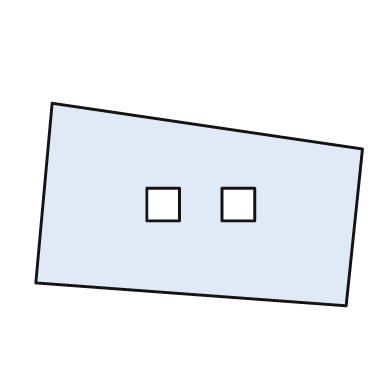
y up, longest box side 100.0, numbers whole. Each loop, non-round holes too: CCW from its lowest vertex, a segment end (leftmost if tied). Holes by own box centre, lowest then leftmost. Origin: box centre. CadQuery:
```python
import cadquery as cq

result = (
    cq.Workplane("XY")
    .moveTo(45.0, -31.0)
    .lineTo(50.0, 17.0)
    .lineTo(-45.0, 31.0)
    .lineTo(-50.0, -24.0)
    .close()
    .moveTo(-16.0, -5.0)
    .lineTo(-6.0, -5.0)
    .lineTo(-6.0, 5.0)
    .lineTo(-16.0, 5.0)
    .close()
    .moveTo(7.0, -5.0)
    .lineTo(17.0, -5.0)
    .lineTo(17.0, 5.0)
    .lineTo(7.0, 5.0)
    .close()
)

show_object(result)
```